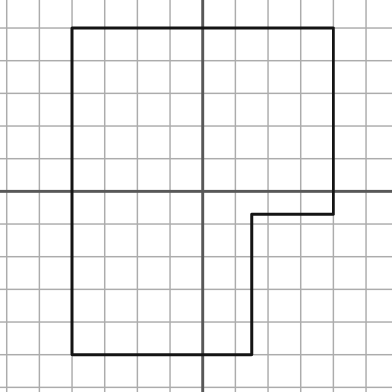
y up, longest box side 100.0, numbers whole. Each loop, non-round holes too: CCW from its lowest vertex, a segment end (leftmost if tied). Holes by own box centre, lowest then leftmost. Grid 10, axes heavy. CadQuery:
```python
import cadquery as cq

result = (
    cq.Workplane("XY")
    .moveTo(-40.0, -50.0)
    .lineTo(15.0, -50.0)
    .lineTo(15.0, -7.0)
    .lineTo(40.0, -7.0)
    .lineTo(40.0, 50.0)
    .lineTo(-40.0, 50.0)
    .close()
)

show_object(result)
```